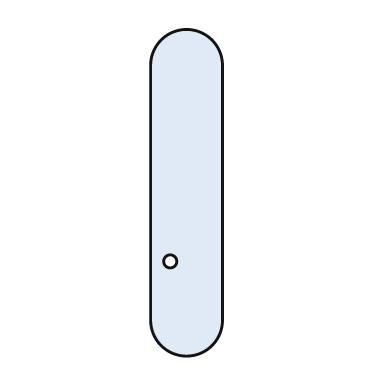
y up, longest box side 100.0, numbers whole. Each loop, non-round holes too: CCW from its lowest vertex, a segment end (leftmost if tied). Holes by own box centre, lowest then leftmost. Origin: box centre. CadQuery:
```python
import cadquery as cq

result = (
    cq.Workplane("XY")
    .moveTo(-11.0, -39.0)
    .threePointArc((0.0, -50.0), (11.0, -39.0))
    .lineTo(11.0, 39.0)
    .threePointArc((0.0, 50.0), (-11.0, 39.0))
    .close()
    .moveTo(-5.0, -21.0)
    .circle(2.0)
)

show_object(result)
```